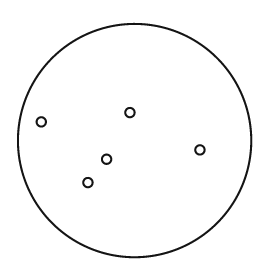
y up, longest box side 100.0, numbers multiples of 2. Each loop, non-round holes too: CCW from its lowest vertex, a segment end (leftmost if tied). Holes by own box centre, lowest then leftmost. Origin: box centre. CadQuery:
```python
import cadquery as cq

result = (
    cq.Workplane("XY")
    .moveTo(0.0, 0.0)
    .circle(50.0)
    .moveTo(-20.0, -18.0)
    .circle(2.0)
    .moveTo(-12.0, -8.0)
    .circle(2.0)
    .moveTo(28.0, -4.0)
    .circle(2.0)
    .moveTo(-40.0, 8.0)
    .circle(2.0)
    .moveTo(-2.0, 12.0)
    .circle(2.0)
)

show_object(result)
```